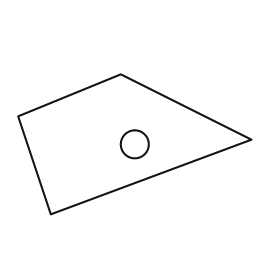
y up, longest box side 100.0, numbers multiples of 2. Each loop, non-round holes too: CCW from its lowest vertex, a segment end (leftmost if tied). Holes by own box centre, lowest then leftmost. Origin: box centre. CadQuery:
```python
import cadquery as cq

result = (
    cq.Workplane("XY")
    .moveTo(-36.0, -30.0)
    .lineTo(50.0, 2.0)
    .lineTo(-6.0, 30.0)
    .lineTo(-50.0, 12.0)
    .close()
    .moveTo(0.0, 0.0)
    .circle(6.0)
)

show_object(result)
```